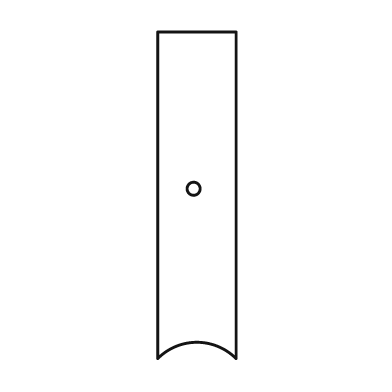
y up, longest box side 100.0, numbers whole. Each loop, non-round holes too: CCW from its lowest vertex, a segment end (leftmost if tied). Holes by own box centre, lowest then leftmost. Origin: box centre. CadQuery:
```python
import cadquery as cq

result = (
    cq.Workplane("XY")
    .moveTo(-12.0, -50.0)
    .threePointArc((0.0, -45.0), (12.0, -50.0))
    .lineTo(12.0, 50.0)
    .lineTo(-12.0, 50.0)
    .close()
    .moveTo(-1.0, 2.0)
    .circle(2.0)
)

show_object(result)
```